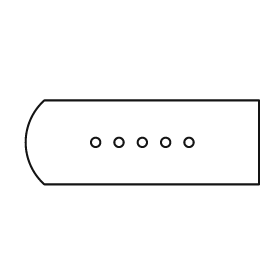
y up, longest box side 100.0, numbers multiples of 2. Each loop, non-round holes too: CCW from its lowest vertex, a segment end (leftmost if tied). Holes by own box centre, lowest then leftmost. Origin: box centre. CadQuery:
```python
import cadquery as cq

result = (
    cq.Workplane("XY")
    .moveTo(-42.0, -18.0)
    .lineTo(50.0, -18.0)
    .lineTo(50.0, 18.0)
    .lineTo(-42.0, 18.0)
    .threePointArc((-50.0, 0.0), (-42.0, -18.0))
    .close()
    .moveTo(-20.0, 0.0)
    .circle(2.0)
    .moveTo(-10.0, 0.0)
    .circle(2.0)
    .moveTo(0.0, 0.0)
    .circle(2.0)
    .moveTo(10.0, 0.0)
    .circle(2.0)
    .moveTo(20.0, 0.0)
    .circle(2.0)
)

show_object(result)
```